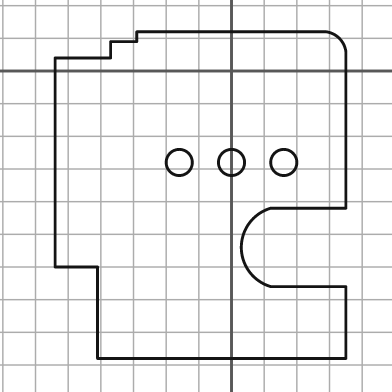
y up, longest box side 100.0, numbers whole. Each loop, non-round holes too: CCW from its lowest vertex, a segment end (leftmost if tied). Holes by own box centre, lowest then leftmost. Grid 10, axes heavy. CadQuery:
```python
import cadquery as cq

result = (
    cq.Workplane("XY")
    .moveTo(-41.0, -88.0)
    .lineTo(35.0, -88.0)
    .lineTo(35.0, -66.0)
    .lineTo(12.0, -66.0)
    .threePointArc((3.0, -54.0), (12.0, -42.0))
    .lineTo(35.0, -42.0)
    .lineTo(35.0, 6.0)
    .threePointArc((33.0, 10.0), (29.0, 12.0))
    .lineTo(-29.0, 12.0)
    .lineTo(-29.0, 9.0)
    .lineTo(-37.0, 9.0)
    .lineTo(-37.0, 4.0)
    .lineTo(-54.0, 4.0)
    .lineTo(-54.0, -60.0)
    .lineTo(-41.0, -60.0)
    .close()
    .moveTo(-16.0, -28.0)
    .circle(4.0)
    .moveTo(0.0, -28.0)
    .circle(4.0)
    .moveTo(16.0, -28.0)
    .circle(4.0)
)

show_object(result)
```